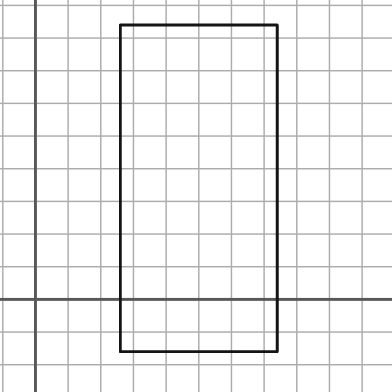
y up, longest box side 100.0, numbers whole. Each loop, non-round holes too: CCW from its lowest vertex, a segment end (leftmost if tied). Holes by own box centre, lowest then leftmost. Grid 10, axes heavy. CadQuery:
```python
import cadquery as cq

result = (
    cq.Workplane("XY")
    .moveTo(26.0, -16.0)
    .lineTo(74.0, -16.0)
    .lineTo(74.0, 84.0)
    .lineTo(26.0, 84.0)
    .close()
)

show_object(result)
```